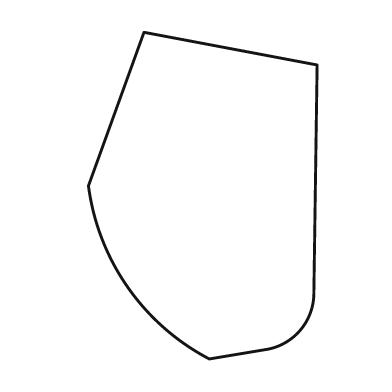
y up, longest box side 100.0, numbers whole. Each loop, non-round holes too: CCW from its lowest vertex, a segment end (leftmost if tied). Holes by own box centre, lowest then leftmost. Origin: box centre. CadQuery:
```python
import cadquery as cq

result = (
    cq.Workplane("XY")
    .moveTo(2.0, -50.0)
    .lineTo(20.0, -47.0)
    .threePointArc((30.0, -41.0), (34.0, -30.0))
    .lineTo(35.0, 40.0)
    .lineTo(-18.0, 50.0)
    .lineTo(-35.0, 3.0)
    .threePointArc((-23.0, -28.0), (2.0, -50.0))
    .close()
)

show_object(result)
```